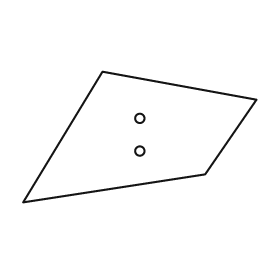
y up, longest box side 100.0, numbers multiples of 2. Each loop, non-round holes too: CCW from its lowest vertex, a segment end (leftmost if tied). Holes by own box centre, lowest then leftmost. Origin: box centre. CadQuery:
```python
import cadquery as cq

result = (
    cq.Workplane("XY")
    .moveTo(-50.0, -28.0)
    .lineTo(28.0, -16.0)
    .lineTo(50.0, 16.0)
    .lineTo(-16.0, 28.0)
    .close()
    .moveTo(0.0, -6.0)
    .circle(2.0)
    .moveTo(0.0, 8.0)
    .circle(2.0)
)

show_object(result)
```